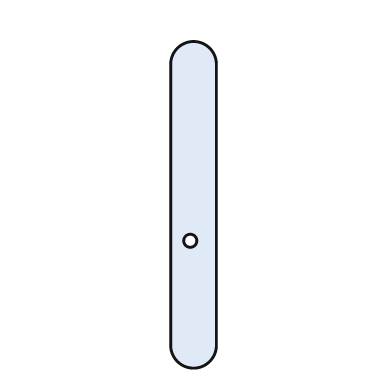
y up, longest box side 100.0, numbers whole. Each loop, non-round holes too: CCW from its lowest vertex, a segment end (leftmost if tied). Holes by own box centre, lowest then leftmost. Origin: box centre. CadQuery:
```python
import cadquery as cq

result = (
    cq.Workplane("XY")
    .moveTo(-7.0, -43.0)
    .threePointArc((0.0, -50.0), (7.0, -43.0))
    .lineTo(7.0, 43.0)
    .threePointArc((0.0, 50.0), (-7.0, 43.0))
    .close()
    .moveTo(-1.0, -11.0)
    .circle(2.0)
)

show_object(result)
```